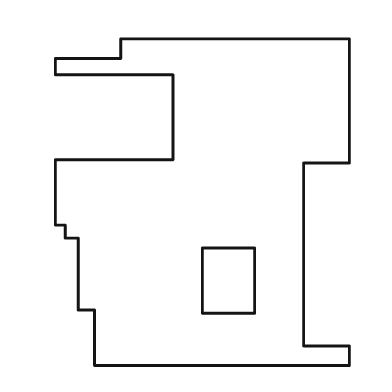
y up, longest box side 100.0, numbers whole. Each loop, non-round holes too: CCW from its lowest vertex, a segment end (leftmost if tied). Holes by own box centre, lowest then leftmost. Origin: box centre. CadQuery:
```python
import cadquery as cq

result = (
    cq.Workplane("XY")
    .moveTo(-33.0, -50.0)
    .lineTo(45.0, -50.0)
    .lineTo(45.0, -44.0)
    .lineTo(31.0, -44.0)
    .lineTo(31.0, 12.0)
    .lineTo(45.0, 12.0)
    .lineTo(45.0, 50.0)
    .lineTo(-25.0, 50.0)
    .lineTo(-25.0, 44.0)
    .lineTo(-45.0, 44.0)
    .lineTo(-45.0, 39.0)
    .lineTo(-9.0, 39.0)
    .lineTo(-9.0, 13.0)
    .lineTo(-45.0, 13.0)
    .lineTo(-45.0, -7.0)
    .lineTo(-42.0, -7.0)
    .lineTo(-42.0, -11.0)
    .lineTo(-38.0, -11.0)
    .lineTo(-38.0, -33.0)
    .lineTo(-33.0, -33.0)
    .close()
    .moveTo(0.0, -34.0)
    .lineTo(16.0, -34.0)
    .lineTo(16.0, -14.0)
    .lineTo(0.0, -14.0)
    .close()
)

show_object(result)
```